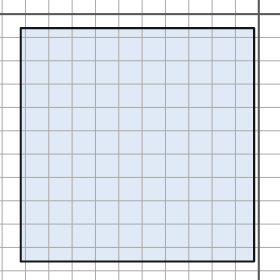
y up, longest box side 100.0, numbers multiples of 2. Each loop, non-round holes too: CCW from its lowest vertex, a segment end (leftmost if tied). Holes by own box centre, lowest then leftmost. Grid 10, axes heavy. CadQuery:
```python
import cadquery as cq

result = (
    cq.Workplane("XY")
    .moveTo(-102.0, -106.0)
    .lineTo(-2.0, -106.0)
    .lineTo(-2.0, -6.0)
    .lineTo(-102.0, -6.0)
    .close()
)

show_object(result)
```